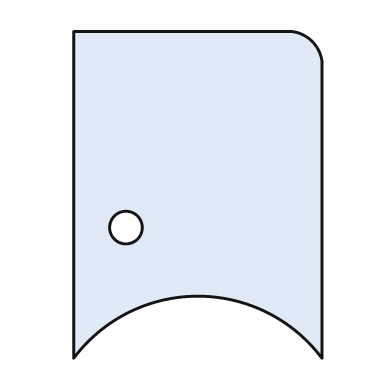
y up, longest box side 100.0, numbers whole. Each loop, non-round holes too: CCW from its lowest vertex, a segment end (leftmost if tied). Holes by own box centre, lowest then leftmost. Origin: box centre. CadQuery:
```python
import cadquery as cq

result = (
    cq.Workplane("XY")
    .moveTo(-38.0, -50.0)
    .threePointArc((0.0, -31.0), (38.0, -50.0))
    .lineTo(38.0, 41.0)
    .threePointArc((35.0, 47.0), (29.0, 50.0))
    .lineTo(-38.0, 50.0)
    .close()
    .moveTo(-22.0, -10.0)
    .circle(5.0)
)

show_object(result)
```